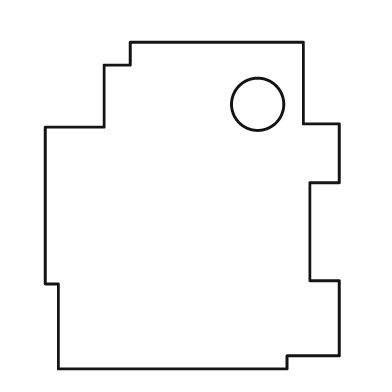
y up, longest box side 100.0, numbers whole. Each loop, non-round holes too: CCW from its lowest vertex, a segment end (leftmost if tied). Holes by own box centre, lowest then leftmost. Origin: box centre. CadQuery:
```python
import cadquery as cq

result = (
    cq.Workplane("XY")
    .moveTo(-41.0, -50.0)
    .lineTo(29.0, -50.0)
    .lineTo(29.0, -46.0)
    .lineTo(45.0, -46.0)
    .lineTo(45.0, -23.0)
    .lineTo(36.0, -23.0)
    .lineTo(36.0, 7.0)
    .lineTo(45.0, 7.0)
    .lineTo(45.0, 25.0)
    .lineTo(34.0, 25.0)
    .lineTo(34.0, 50.0)
    .lineTo(-19.0, 50.0)
    .lineTo(-19.0, 43.0)
    .lineTo(-27.0, 43.0)
    .lineTo(-27.0, 24.0)
    .lineTo(-45.0, 24.0)
    .lineTo(-45.0, -24.0)
    .lineTo(-41.0, -24.0)
    .close()
    .moveTo(20.0, 31.0)
    .circle(8.0)
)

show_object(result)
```